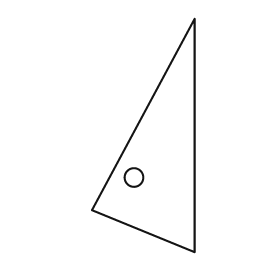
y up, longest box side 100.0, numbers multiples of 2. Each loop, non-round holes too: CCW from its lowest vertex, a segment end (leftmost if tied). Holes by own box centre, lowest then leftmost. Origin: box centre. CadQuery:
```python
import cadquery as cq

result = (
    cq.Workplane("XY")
    .moveTo(22.0, -50.0)
    .lineTo(22.0, 50.0)
    .lineTo(-22.0, -32.0)
    .close()
    .moveTo(-4.0, -18.0)
    .circle(4.0)
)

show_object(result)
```